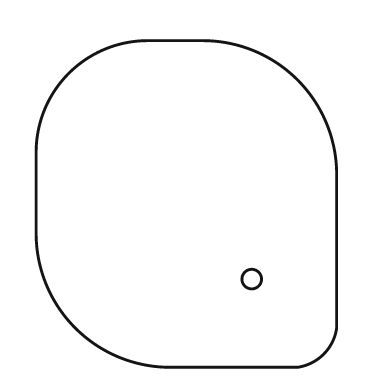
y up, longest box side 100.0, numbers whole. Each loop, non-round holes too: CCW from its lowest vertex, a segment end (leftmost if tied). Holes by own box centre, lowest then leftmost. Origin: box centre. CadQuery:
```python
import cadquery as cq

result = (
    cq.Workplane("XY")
    .moveTo(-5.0, -50.0)
    .lineTo(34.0, -50.0)
    .threePointArc((42.0, -46.0), (46.0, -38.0))
    .lineTo(46.0, 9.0)
    .threePointArc((34.0, 38.0), (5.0, 50.0))
    .lineTo(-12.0, 50.0)
    .threePointArc((-36.0, 40.0), (-46.0, 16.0))
    .lineTo(-46.0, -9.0)
    .threePointArc((-34.0, -38.0), (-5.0, -50.0))
    .close()
    .moveTo(20.0, -23.0)
    .circle(3.0)
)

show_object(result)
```